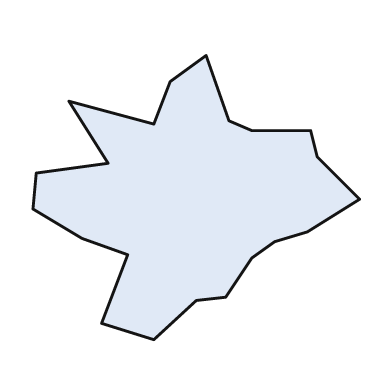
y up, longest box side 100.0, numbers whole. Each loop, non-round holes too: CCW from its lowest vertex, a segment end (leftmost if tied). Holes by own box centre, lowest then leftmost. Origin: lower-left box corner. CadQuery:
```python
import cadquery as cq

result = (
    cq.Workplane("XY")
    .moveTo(37.0, 0.0)
    .lineTo(50.0, 12.0)
    .lineTo(59.0, 13.0)
    .lineTo(67.0, 25.0)
    .lineTo(74.0, 30.0)
    .lineTo(84.0, 33.0)
    .lineTo(100.0, 43.0)
    .lineTo(87.0, 56.0)
    .lineTo(85.0, 64.0)
    .lineTo(67.0, 64.0)
    .lineTo(60.0, 67.0)
    .lineTo(53.0, 87.0)
    .lineTo(42.0, 79.0)
    .lineTo(37.0, 66.0)
    .lineTo(11.0, 73.0)
    .lineTo(23.0, 54.0)
    .lineTo(1.0, 51.0)
    .lineTo(0.0, 40.0)
    .lineTo(15.0, 31.0)
    .lineTo(29.0, 26.0)
    .lineTo(21.0, 5.0)
    .close()
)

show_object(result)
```